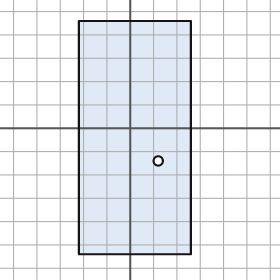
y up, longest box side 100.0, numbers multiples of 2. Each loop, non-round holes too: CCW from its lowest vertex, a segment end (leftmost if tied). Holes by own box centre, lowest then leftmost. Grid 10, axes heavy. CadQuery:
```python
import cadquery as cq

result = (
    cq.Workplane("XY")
    .moveTo(-22.0, -54.0)
    .lineTo(26.0, -54.0)
    .lineTo(26.0, 46.0)
    .lineTo(-22.0, 46.0)
    .close()
    .moveTo(12.0, -14.0)
    .circle(2.0)
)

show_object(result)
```